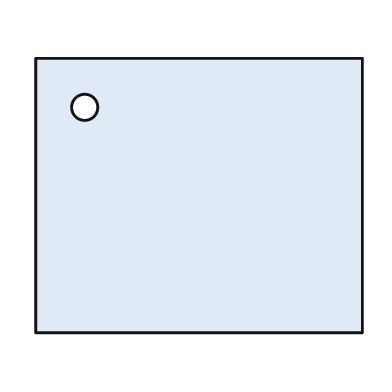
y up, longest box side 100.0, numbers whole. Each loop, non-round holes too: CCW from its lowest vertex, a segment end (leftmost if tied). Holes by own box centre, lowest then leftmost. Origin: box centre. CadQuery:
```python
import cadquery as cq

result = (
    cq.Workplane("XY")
    .moveTo(-50.0, -42.0)
    .lineTo(50.0, -42.0)
    .lineTo(50.0, 42.0)
    .lineTo(-50.0, 42.0)
    .close()
    .moveTo(-35.0, 27.0)
    .circle(4.0)
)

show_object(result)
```